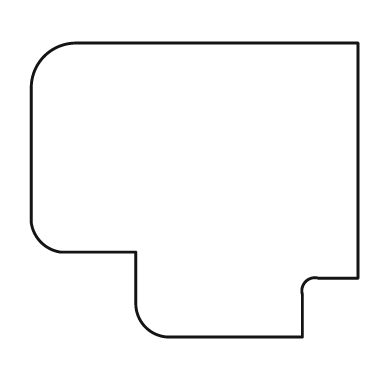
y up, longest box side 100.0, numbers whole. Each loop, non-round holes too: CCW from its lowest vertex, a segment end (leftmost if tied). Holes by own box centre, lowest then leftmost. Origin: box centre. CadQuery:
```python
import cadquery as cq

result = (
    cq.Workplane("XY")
    .moveTo(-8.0, -45.0)
    .lineTo(33.0, -45.0)
    .lineTo(33.0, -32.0)
    .threePointArc((34.0, -28.0), (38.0, -27.0))
    .lineTo(50.0, -27.0)
    .lineTo(50.0, 45.0)
    .lineTo(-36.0, 45.0)
    .threePointArc((-46.0, 41.0), (-50.0, 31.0))
    .lineTo(-50.0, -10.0)
    .threePointArc((-47.0, -16.0), (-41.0, -19.0))
    .lineTo(-18.0, -19.0)
    .lineTo(-18.0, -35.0)
    .threePointArc((-15.0, -42.0), (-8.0, -45.0))
    .close()
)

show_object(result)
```